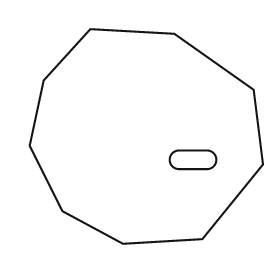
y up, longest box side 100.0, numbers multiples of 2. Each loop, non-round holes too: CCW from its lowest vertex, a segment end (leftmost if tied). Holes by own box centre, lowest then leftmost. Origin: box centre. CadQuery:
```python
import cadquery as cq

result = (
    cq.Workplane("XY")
    .moveTo(-10.0, -46.0)
    .lineTo(24.0, -44.0)
    .lineTo(50.0, -12.0)
    .lineTo(46.0, 20.0)
    .lineTo(12.0, 44.0)
    .lineTo(-24.0, 46.0)
    .lineTo(-44.0, 24.0)
    .lineTo(-50.0, -4.0)
    .lineTo(-36.0, -32.0)
    .close()
    .moveTo(14.0, -14.0)
    .lineTo(26.0, -14.0)
    .threePointArc((30.0, -10.0), (26.0, -6.0))
    .lineTo(14.0, -6.0)
    .threePointArc((10.0, -10.0), (14.0, -14.0))
    .close()
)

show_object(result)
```